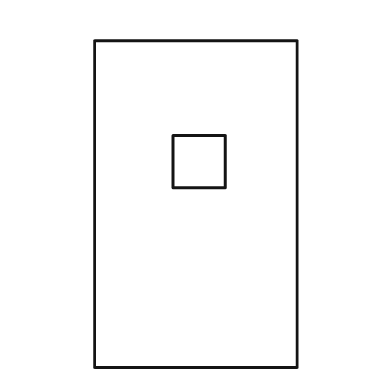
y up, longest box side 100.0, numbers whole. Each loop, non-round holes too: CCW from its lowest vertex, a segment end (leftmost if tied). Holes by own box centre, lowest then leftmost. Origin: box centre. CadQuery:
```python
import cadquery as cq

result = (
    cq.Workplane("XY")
    .moveTo(-31.0, -50.0)
    .lineTo(31.0, -50.0)
    .lineTo(31.0, 50.0)
    .lineTo(-31.0, 50.0)
    .close()
    .moveTo(-7.0, 5.0)
    .lineTo(9.0, 5.0)
    .lineTo(9.0, 21.0)
    .lineTo(-7.0, 21.0)
    .close()
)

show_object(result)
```